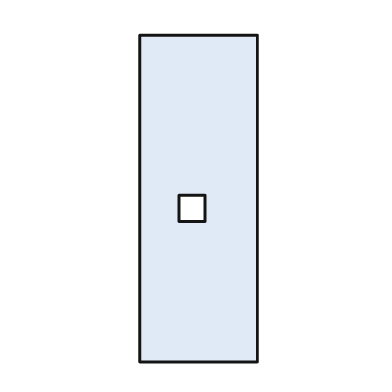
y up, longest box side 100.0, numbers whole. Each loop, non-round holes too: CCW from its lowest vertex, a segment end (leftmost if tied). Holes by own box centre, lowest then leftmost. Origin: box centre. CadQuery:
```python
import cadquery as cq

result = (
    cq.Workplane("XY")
    .moveTo(-18.0, -50.0)
    .lineTo(18.0, -50.0)
    .lineTo(18.0, 50.0)
    .lineTo(-18.0, 50.0)
    .close()
    .moveTo(-6.0, -7.0)
    .lineTo(2.0, -7.0)
    .lineTo(2.0, 1.0)
    .lineTo(-6.0, 1.0)
    .close()
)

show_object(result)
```